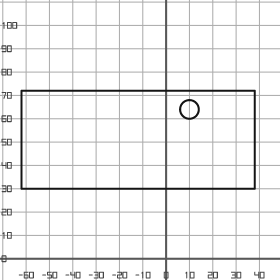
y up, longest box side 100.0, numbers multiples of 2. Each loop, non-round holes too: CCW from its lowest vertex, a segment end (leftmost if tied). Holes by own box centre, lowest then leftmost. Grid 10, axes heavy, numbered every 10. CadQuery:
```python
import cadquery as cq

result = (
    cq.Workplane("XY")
    .moveTo(-62.0, 30.0)
    .lineTo(38.0, 30.0)
    .lineTo(38.0, 72.0)
    .lineTo(-62.0, 72.0)
    .close()
    .moveTo(10.0, 64.0)
    .circle(4.0)
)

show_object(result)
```